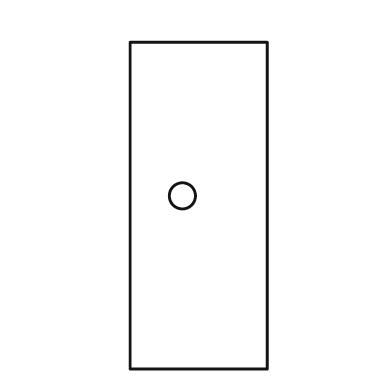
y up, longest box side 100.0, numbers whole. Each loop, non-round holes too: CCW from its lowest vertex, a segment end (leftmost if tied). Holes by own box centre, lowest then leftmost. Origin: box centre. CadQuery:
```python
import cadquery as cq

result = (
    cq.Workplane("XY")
    .moveTo(-21.0, -50.0)
    .lineTo(21.0, -50.0)
    .lineTo(21.0, 50.0)
    .lineTo(-21.0, 50.0)
    .close()
    .moveTo(-5.0, 3.0)
    .circle(4.0)
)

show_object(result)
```